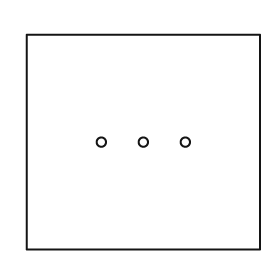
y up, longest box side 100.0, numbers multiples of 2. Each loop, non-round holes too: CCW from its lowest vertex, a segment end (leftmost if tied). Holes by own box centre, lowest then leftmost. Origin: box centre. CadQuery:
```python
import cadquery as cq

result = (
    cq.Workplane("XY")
    .moveTo(-50.0, -46.0)
    .lineTo(50.0, -46.0)
    .lineTo(50.0, 46.0)
    .lineTo(-50.0, 46.0)
    .close()
    .moveTo(-18.0, 0.0)
    .circle(2.0)
    .moveTo(0.0, 0.0)
    .circle(2.0)
    .moveTo(18.0, 0.0)
    .circle(2.0)
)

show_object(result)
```